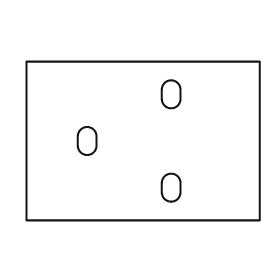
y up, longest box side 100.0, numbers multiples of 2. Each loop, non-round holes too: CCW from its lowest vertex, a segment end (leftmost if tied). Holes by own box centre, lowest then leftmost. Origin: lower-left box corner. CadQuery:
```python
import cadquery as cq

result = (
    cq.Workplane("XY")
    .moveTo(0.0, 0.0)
    .lineTo(100.0, 0.0)
    .lineTo(100.0, 68.0)
    .lineTo(0.0, 68.0)
    .close()
    .moveTo(58.0, 12.0)
    .threePointArc((62.0, 8.0), (66.0, 12.0))
    .lineTo(66.0, 16.0)
    .threePointArc((62.0, 20.0), (58.0, 16.0))
    .close()
    .moveTo(22.0, 32.0)
    .threePointArc((26.0, 28.0), (30.0, 32.0))
    .lineTo(30.0, 36.0)
    .threePointArc((26.0, 40.0), (22.0, 36.0))
    .close()
    .moveTo(58.0, 52.0)
    .threePointArc((62.0, 48.0), (66.0, 52.0))
    .lineTo(66.0, 56.0)
    .threePointArc((62.0, 60.0), (58.0, 56.0))
    .close()
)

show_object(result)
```